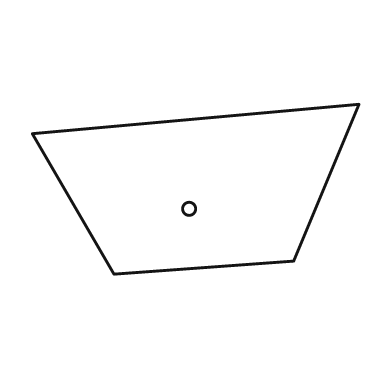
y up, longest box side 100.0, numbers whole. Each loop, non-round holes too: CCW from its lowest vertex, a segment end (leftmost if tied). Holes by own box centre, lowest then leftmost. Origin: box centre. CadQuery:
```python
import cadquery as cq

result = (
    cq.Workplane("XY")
    .moveTo(-25.0, -26.0)
    .lineTo(30.0, -22.0)
    .lineTo(50.0, 26.0)
    .lineTo(-50.0, 17.0)
    .close()
    .moveTo(-2.0, -6.0)
    .circle(2.0)
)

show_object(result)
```